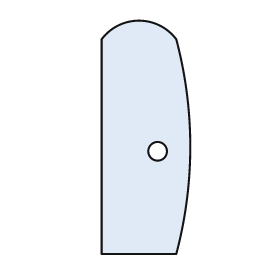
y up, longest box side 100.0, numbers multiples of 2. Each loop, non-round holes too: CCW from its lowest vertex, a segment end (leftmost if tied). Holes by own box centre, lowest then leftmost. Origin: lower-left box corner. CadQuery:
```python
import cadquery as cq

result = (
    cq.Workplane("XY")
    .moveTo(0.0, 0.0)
    .lineTo(32.0, 0.0)
    .threePointArc((38.0, 46.0), (32.0, 92.0))
    .threePointArc((16.0, 100.0), (0.0, 92.0))
    .close()
    .moveTo(24.0, 44.0)
    .circle(4.0)
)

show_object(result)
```